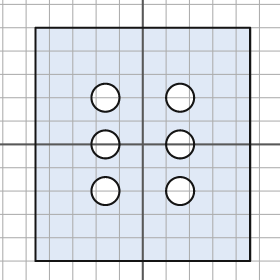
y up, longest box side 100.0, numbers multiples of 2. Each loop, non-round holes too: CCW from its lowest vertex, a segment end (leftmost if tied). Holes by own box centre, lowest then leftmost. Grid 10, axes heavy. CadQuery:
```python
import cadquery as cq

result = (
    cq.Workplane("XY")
    .moveTo(-46.0, -50.0)
    .lineTo(46.0, -50.0)
    .lineTo(46.0, 50.0)
    .lineTo(-46.0, 50.0)
    .close()
    .moveTo(-16.0, -20.0)
    .circle(6.0)
    .moveTo(16.0, -20.0)
    .circle(6.0)
    .moveTo(-16.0, 0.0)
    .circle(6.0)
    .moveTo(16.0, 0.0)
    .circle(6.0)
    .moveTo(-16.0, 20.0)
    .circle(6.0)
    .moveTo(16.0, 20.0)
    .circle(6.0)
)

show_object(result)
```